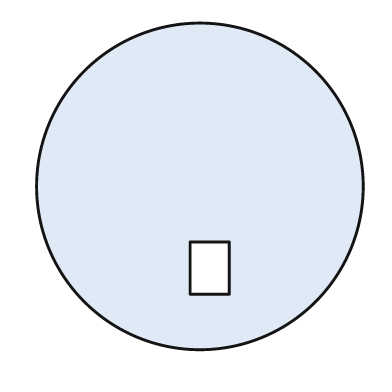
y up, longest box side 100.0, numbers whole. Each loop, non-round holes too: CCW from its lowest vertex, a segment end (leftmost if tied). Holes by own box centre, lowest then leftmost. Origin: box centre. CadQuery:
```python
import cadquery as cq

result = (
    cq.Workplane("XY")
    .moveTo(0.0, 0.0)
    .circle(50.0)
    .moveTo(-3.0, -33.0)
    .lineTo(9.0, -33.0)
    .lineTo(9.0, -17.0)
    .lineTo(-3.0, -17.0)
    .close()
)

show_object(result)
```